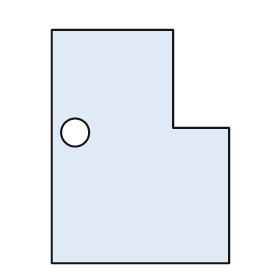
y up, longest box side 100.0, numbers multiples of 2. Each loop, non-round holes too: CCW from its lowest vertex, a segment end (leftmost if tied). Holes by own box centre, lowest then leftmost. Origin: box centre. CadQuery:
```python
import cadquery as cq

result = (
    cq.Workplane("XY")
    .moveTo(-38.0, -50.0)
    .lineTo(38.0, -50.0)
    .lineTo(38.0, 8.0)
    .lineTo(14.0, 8.0)
    .lineTo(14.0, 50.0)
    .lineTo(-38.0, 50.0)
    .close()
    .moveTo(-28.0, 6.0)
    .circle(6.0)
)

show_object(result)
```